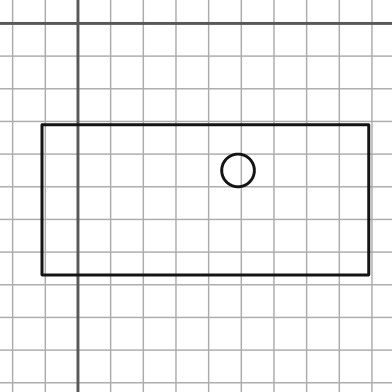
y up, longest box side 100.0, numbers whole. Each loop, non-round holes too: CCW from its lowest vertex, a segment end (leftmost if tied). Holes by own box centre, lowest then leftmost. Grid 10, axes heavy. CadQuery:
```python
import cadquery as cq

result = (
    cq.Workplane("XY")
    .moveTo(-11.0, -77.0)
    .lineTo(89.0, -77.0)
    .lineTo(89.0, -31.0)
    .lineTo(-11.0, -31.0)
    .close()
    .moveTo(49.0, -45.0)
    .circle(5.0)
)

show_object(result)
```